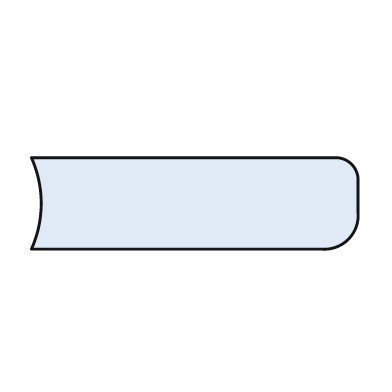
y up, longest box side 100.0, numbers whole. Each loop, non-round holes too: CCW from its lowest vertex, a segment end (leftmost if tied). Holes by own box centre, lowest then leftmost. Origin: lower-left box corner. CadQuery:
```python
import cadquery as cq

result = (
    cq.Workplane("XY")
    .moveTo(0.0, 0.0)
    .lineTo(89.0, 0.0)
    .threePointArc((97.0, 3.0), (100.0, 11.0))
    .lineTo(100.0, 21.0)
    .threePointArc((98.0, 26.0), (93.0, 28.0))
    .lineTo(0.0, 28.0)
    .threePointArc((3.0, 14.0), (0.0, 0.0))
    .close()
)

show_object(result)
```